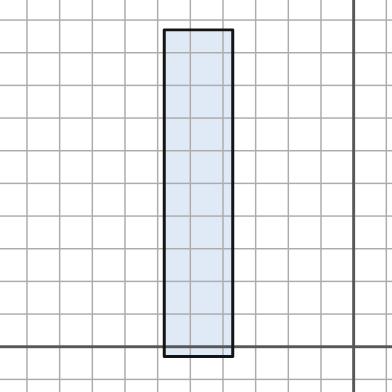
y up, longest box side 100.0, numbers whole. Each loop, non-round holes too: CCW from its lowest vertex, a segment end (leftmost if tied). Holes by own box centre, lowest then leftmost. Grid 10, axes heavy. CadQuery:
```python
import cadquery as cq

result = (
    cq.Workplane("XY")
    .moveTo(-58.0, -3.0)
    .lineTo(-37.0, -3.0)
    .lineTo(-37.0, 97.0)
    .lineTo(-58.0, 97.0)
    .close()
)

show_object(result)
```